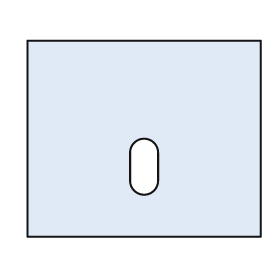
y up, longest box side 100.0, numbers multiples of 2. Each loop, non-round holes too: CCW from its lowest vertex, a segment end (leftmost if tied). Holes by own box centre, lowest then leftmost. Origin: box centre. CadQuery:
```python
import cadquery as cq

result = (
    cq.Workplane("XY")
    .moveTo(-50.0, -42.0)
    .lineTo(50.0, -42.0)
    .lineTo(50.0, 42.0)
    .lineTo(-50.0, 42.0)
    .close()
    .moveTo(-6.0, -18.0)
    .threePointArc((0.0, -24.0), (6.0, -18.0))
    .lineTo(6.0, -6.0)
    .threePointArc((0.0, 0.0), (-6.0, -6.0))
    .close()
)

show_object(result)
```